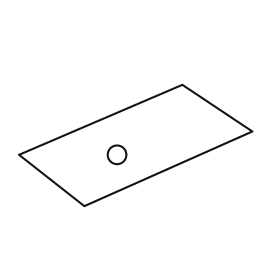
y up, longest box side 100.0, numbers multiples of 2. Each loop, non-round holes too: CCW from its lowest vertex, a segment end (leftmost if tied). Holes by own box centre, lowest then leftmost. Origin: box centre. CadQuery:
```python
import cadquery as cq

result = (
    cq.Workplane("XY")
    .moveTo(-22.0, -26.0)
    .lineTo(50.0, 6.0)
    .lineTo(20.0, 26.0)
    .lineTo(-50.0, -4.0)
    .close()
    .moveTo(-8.0, -4.0)
    .circle(4.0)
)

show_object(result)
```